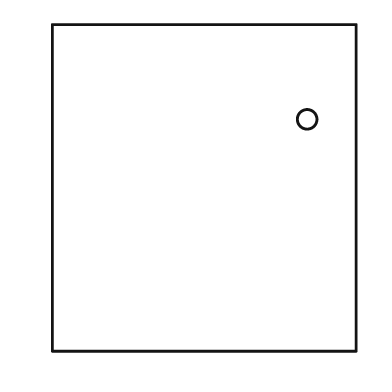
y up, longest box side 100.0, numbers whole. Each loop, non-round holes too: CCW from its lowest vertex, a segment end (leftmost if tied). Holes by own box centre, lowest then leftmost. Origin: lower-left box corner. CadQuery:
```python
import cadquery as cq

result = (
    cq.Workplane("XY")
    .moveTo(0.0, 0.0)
    .lineTo(93.0, 0.0)
    .lineTo(93.0, 100.0)
    .lineTo(0.0, 100.0)
    .close()
    .moveTo(78.0, 71.0)
    .circle(3.0)
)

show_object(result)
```